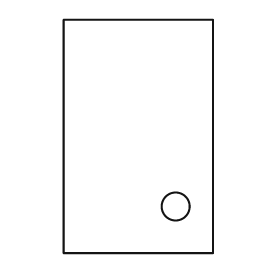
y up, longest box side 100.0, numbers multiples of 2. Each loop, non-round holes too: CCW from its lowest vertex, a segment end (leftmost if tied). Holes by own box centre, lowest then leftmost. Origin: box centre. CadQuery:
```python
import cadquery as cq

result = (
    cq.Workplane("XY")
    .moveTo(-32.0, -50.0)
    .lineTo(32.0, -50.0)
    .lineTo(32.0, 50.0)
    .lineTo(-32.0, 50.0)
    .close()
    .moveTo(16.0, -30.0)
    .circle(6.0)
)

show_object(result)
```